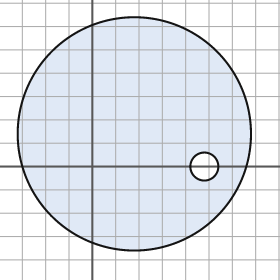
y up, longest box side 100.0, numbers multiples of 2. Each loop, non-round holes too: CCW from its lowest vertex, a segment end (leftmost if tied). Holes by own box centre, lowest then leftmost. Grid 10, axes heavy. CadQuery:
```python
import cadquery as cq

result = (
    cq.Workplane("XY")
    .moveTo(18.0, 14.0)
    .circle(50.0)
    .moveTo(48.0, 0.0)
    .circle(6.0)
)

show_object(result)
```